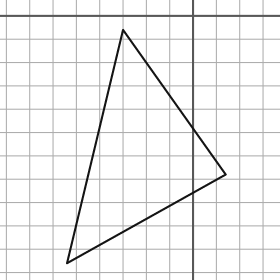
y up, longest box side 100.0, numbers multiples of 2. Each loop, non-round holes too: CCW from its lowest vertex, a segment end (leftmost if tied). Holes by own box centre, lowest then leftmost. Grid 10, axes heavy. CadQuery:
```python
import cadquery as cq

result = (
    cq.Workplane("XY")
    .moveTo(-54.0, -106.0)
    .lineTo(14.0, -68.0)
    .lineTo(-30.0, -6.0)
    .close()
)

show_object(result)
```